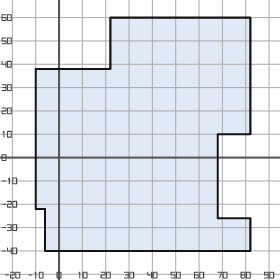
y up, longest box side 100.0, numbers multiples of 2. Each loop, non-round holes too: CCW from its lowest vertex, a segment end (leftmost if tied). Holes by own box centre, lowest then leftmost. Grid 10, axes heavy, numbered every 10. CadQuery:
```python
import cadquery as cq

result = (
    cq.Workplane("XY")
    .moveTo(-6.0, -40.0)
    .lineTo(82.0, -40.0)
    .lineTo(82.0, -26.0)
    .lineTo(68.0, -26.0)
    .lineTo(68.0, 10.0)
    .lineTo(82.0, 10.0)
    .lineTo(82.0, 60.0)
    .lineTo(22.0, 60.0)
    .lineTo(22.0, 38.0)
    .lineTo(-10.0, 38.0)
    .lineTo(-10.0, -22.0)
    .lineTo(-6.0, -22.0)
    .close()
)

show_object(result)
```